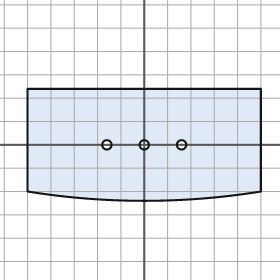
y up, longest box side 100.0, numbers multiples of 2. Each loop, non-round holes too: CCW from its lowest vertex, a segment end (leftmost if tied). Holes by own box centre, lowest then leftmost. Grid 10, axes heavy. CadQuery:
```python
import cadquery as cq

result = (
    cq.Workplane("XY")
    .moveTo(-50.0, -20.0)
    .threePointArc((0.0, -24.0), (50.0, -20.0))
    .lineTo(50.0, 24.0)
    .lineTo(-50.0, 24.0)
    .close()
    .moveTo(-16.0, 0.0)
    .circle(2.0)
    .moveTo(0.0, 0.0)
    .circle(2.0)
    .moveTo(16.0, 0.0)
    .circle(2.0)
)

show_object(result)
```